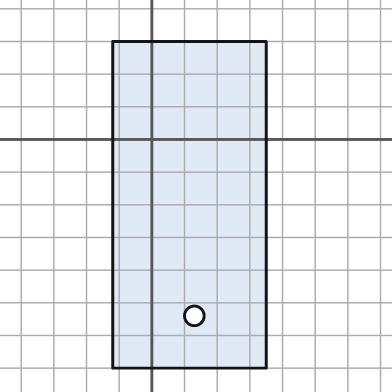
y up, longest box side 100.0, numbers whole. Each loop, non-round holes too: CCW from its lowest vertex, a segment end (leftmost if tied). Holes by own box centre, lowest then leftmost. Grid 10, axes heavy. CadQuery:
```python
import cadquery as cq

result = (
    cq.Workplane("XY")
    .moveTo(-12.0, -70.0)
    .lineTo(35.0, -70.0)
    .lineTo(35.0, 30.0)
    .lineTo(-12.0, 30.0)
    .close()
    .moveTo(13.0, -54.0)
    .circle(3.0)
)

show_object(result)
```